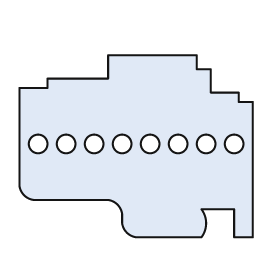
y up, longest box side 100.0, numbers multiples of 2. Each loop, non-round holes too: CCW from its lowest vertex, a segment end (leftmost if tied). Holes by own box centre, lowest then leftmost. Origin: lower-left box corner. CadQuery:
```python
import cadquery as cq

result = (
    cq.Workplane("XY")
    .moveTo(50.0, 0.0)
    .lineTo(78.0, 0.0)
    .threePointArc((80.0, 6.0), (78.0, 12.0))
    .lineTo(92.0, 12.0)
    .lineTo(92.0, 0.0)
    .lineTo(100.0, 0.0)
    .lineTo(100.0, 58.0)
    .lineTo(94.0, 58.0)
    .lineTo(94.0, 62.0)
    .lineTo(82.0, 62.0)
    .lineTo(82.0, 72.0)
    .lineTo(76.0, 72.0)
    .lineTo(76.0, 78.0)
    .lineTo(38.0, 78.0)
    .lineTo(38.0, 68.0)
    .lineTo(12.0, 68.0)
    .lineTo(12.0, 64.0)
    .lineTo(0.0, 64.0)
    .lineTo(0.0, 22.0)
    .threePointArc((2.0, 18.0), (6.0, 16.0))
    .lineTo(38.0, 16.0)
    .threePointArc((42.0, 14.0), (44.0, 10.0))
    .lineTo(44.0, 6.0)
    .threePointArc((46.0, 2.0), (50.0, 0.0))
    .close()
    .moveTo(8.0, 40.0)
    .circle(4.0)
    .moveTo(20.0, 40.0)
    .circle(4.0)
    .moveTo(32.0, 40.0)
    .circle(4.0)
    .moveTo(44.0, 40.0)
    .circle(4.0)
    .moveTo(56.0, 40.0)
    .circle(4.0)
    .moveTo(68.0, 40.0)
    .circle(4.0)
    .moveTo(80.0, 40.0)
    .circle(4.0)
    .moveTo(92.0, 40.0)
    .circle(4.0)
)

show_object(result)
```